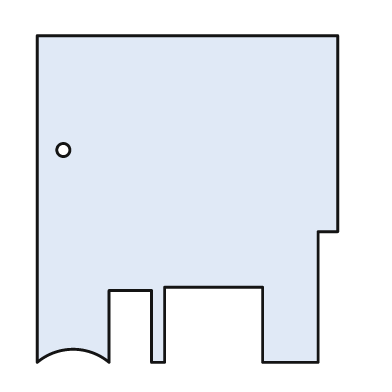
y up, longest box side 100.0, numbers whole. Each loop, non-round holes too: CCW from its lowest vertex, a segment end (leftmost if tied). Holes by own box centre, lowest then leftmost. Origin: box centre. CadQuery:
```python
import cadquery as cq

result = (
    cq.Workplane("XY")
    .moveTo(-46.0, -50.0)
    .threePointArc((-35.0, -46.0), (-24.0, -50.0))
    .lineTo(-24.0, -28.0)
    .lineTo(-11.0, -28.0)
    .lineTo(-11.0, -50.0)
    .lineTo(-7.0, -50.0)
    .lineTo(-7.0, -27.0)
    .lineTo(23.0, -27.0)
    .lineTo(23.0, -50.0)
    .lineTo(40.0, -50.0)
    .lineTo(40.0, -10.0)
    .lineTo(46.0, -10.0)
    .lineTo(46.0, 50.0)
    .lineTo(-46.0, 50.0)
    .close()
    .moveTo(-38.0, 15.0)
    .circle(2.0)
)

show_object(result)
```